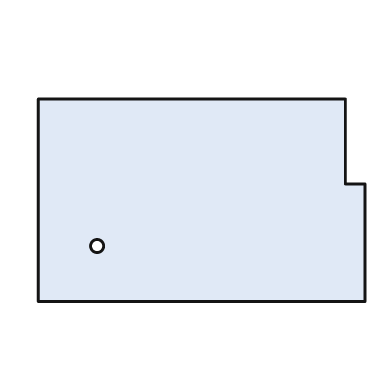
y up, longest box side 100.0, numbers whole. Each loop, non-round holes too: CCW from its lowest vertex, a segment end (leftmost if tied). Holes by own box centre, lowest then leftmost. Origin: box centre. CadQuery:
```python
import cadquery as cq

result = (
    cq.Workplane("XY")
    .moveTo(-50.0, -31.0)
    .lineTo(50.0, -31.0)
    .lineTo(50.0, 5.0)
    .lineTo(44.0, 5.0)
    .lineTo(44.0, 31.0)
    .lineTo(-50.0, 31.0)
    .close()
    .moveTo(-32.0, -14.0)
    .circle(2.0)
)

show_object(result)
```